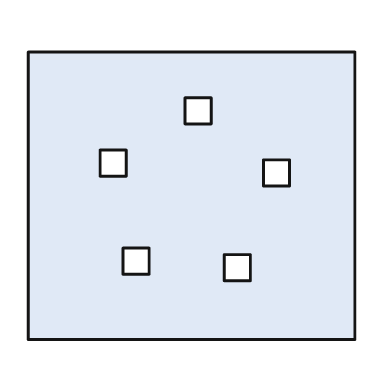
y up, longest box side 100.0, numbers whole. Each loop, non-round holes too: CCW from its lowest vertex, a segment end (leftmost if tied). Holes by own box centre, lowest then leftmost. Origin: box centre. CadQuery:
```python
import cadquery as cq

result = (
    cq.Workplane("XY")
    .moveTo(-50.0, -44.0)
    .lineTo(50.0, -44.0)
    .lineTo(50.0, 44.0)
    .lineTo(-50.0, 44.0)
    .close()
    .moveTo(10.0, -26.0)
    .lineTo(18.0, -26.0)
    .lineTo(18.0, -18.0)
    .lineTo(10.0, -18.0)
    .close()
    .moveTo(-21.0, -24.0)
    .lineTo(-13.0, -24.0)
    .lineTo(-13.0, -16.0)
    .lineTo(-21.0, -16.0)
    .close()
    .moveTo(22.0, 3.0)
    .lineTo(30.0, 3.0)
    .lineTo(30.0, 11.0)
    .lineTo(22.0, 11.0)
    .close()
    .moveTo(-28.0, 6.0)
    .lineTo(-20.0, 6.0)
    .lineTo(-20.0, 14.0)
    .lineTo(-28.0, 14.0)
    .close()
    .moveTo(-2.0, 22.0)
    .lineTo(6.0, 22.0)
    .lineTo(6.0, 30.0)
    .lineTo(-2.0, 30.0)
    .close()
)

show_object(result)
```